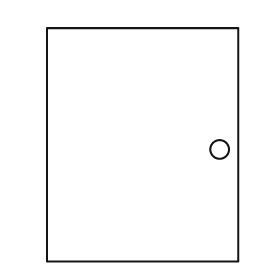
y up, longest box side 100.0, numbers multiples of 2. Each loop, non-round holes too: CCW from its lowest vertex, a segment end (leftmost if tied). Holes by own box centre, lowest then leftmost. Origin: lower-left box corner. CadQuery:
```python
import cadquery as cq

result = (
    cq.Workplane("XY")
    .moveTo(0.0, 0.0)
    .lineTo(82.0, 0.0)
    .lineTo(82.0, 100.0)
    .lineTo(0.0, 100.0)
    .close()
    .moveTo(74.0, 48.0)
    .circle(4.0)
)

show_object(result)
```